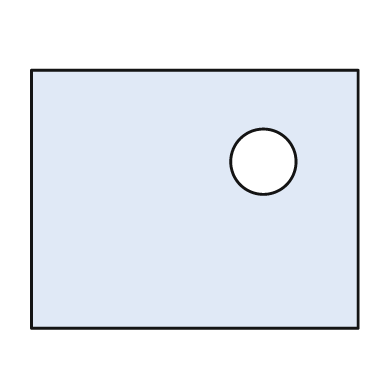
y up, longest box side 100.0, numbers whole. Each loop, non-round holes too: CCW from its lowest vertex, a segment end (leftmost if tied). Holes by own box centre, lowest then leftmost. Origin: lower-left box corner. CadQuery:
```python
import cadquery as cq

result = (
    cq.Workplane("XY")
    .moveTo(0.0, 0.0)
    .lineTo(100.0, 0.0)
    .lineTo(100.0, 79.0)
    .lineTo(0.0, 79.0)
    .close()
    .moveTo(71.0, 51.0)
    .circle(10.0)
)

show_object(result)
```